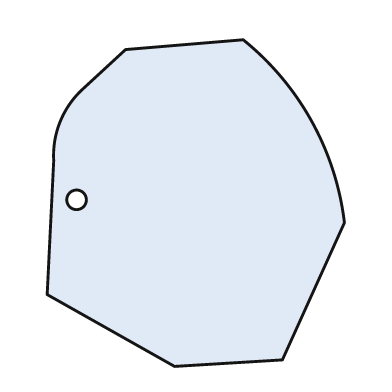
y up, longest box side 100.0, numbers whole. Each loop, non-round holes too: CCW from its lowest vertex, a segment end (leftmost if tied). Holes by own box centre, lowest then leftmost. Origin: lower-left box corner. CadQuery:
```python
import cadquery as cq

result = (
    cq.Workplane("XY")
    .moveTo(39.0, 0.0)
    .lineTo(72.0, 2.0)
    .lineTo(91.0, 44.0)
    .threePointArc((81.0, 75.0), (60.0, 100.0))
    .lineTo(24.0, 97.0)
    .lineTo(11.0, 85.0)
    .threePointArc((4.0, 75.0), (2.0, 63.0))
    .lineTo(0.0, 22.0)
    .close()
    .moveTo(9.0, 51.0)
    .circle(3.0)
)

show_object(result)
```